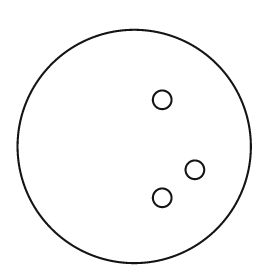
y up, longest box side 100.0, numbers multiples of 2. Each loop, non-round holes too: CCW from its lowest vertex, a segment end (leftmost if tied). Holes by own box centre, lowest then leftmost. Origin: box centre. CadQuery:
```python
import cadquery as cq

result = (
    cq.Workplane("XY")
    .moveTo(0.0, 0.0)
    .circle(50.0)
    .moveTo(12.0, -22.0)
    .circle(4.0)
    .moveTo(26.0, -10.0)
    .circle(4.0)
    .moveTo(12.0, 20.0)
    .circle(4.0)
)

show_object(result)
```